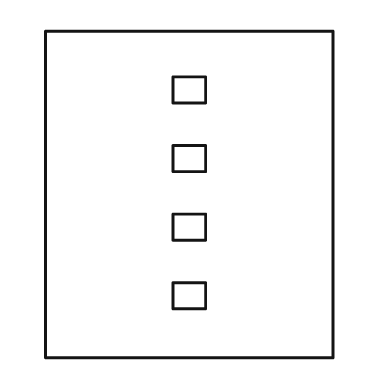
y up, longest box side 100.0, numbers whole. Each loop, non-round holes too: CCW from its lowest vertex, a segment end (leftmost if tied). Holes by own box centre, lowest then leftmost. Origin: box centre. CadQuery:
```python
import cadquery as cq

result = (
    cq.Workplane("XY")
    .moveTo(-44.0, -50.0)
    .lineTo(44.0, -50.0)
    .lineTo(44.0, 50.0)
    .lineTo(-44.0, 50.0)
    .close()
    .moveTo(-5.0, -35.0)
    .lineTo(5.0, -35.0)
    .lineTo(5.0, -27.0)
    .lineTo(-5.0, -27.0)
    .close()
    .moveTo(-5.0, -14.0)
    .lineTo(5.0, -14.0)
    .lineTo(5.0, -6.0)
    .lineTo(-5.0, -6.0)
    .close()
    .moveTo(-5.0, 7.0)
    .lineTo(5.0, 7.0)
    .lineTo(5.0, 15.0)
    .lineTo(-5.0, 15.0)
    .close()
    .moveTo(-5.0, 28.0)
    .lineTo(5.0, 28.0)
    .lineTo(5.0, 36.0)
    .lineTo(-5.0, 36.0)
    .close()
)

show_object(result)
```